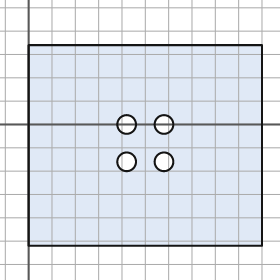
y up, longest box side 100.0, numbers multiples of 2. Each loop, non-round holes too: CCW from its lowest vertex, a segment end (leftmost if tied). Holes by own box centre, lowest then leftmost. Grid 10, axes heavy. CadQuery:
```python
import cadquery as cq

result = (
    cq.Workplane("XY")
    .moveTo(0.0, -52.0)
    .lineTo(100.0, -52.0)
    .lineTo(100.0, 34.0)
    .lineTo(0.0, 34.0)
    .close()
    .moveTo(42.0, -16.0)
    .circle(4.0)
    .moveTo(58.0, -16.0)
    .circle(4.0)
    .moveTo(42.0, 0.0)
    .circle(4.0)
    .moveTo(58.0, 0.0)
    .circle(4.0)
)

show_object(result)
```